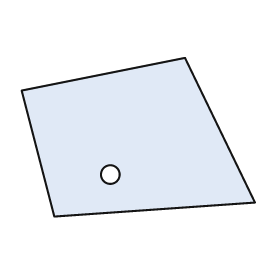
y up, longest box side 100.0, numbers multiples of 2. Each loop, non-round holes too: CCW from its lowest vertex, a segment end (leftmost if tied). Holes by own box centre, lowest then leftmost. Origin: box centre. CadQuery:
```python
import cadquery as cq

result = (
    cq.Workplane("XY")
    .moveTo(-36.0, -34.0)
    .lineTo(50.0, -28.0)
    .lineTo(20.0, 34.0)
    .lineTo(-50.0, 20.0)
    .close()
    .moveTo(-12.0, -16.0)
    .circle(4.0)
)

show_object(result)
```